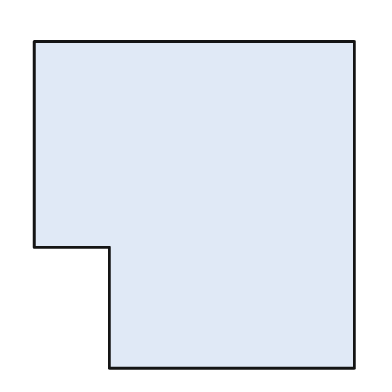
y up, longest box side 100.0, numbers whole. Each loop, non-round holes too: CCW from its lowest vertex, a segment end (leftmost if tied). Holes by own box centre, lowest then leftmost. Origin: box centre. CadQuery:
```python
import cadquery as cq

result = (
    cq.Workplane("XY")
    .moveTo(-26.0, -50.0)
    .lineTo(49.0, -50.0)
    .lineTo(49.0, 50.0)
    .lineTo(-49.0, 50.0)
    .lineTo(-49.0, -13.0)
    .lineTo(-26.0, -13.0)
    .close()
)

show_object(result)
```